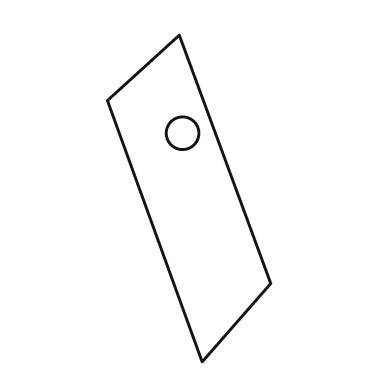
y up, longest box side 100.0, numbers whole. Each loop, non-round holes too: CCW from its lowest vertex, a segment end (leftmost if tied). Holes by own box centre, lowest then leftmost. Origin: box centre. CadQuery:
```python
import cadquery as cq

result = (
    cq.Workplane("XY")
    .moveTo(4.0, -50.0)
    .lineTo(25.0, -26.0)
    .lineTo(-3.0, 50.0)
    .lineTo(-25.0, 30.0)
    .close()
    .moveTo(-2.0, 20.0)
    .circle(5.0)
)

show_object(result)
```